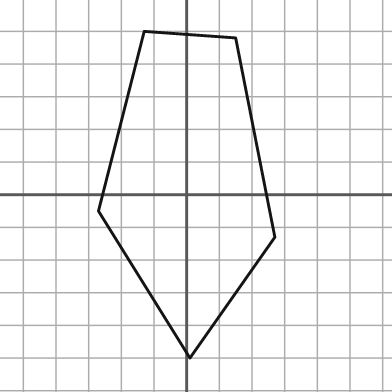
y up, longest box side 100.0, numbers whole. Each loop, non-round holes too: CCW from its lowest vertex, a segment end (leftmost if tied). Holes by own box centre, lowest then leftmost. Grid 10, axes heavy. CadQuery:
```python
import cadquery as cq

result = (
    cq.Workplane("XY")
    .moveTo(1.0, -50.0)
    .lineTo(27.0, -13.0)
    .lineTo(15.0, 48.0)
    .lineTo(-13.0, 50.0)
    .lineTo(-27.0, -5.0)
    .close()
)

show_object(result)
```